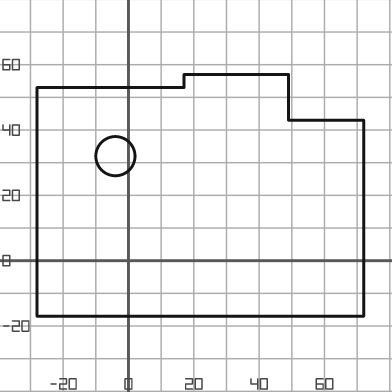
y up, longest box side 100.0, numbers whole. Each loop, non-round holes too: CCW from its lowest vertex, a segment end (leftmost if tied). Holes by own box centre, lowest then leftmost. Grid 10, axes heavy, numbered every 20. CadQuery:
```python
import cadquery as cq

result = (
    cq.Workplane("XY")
    .moveTo(-28.0, -17.0)
    .lineTo(72.0, -17.0)
    .lineTo(72.0, 43.0)
    .lineTo(49.0, 43.0)
    .lineTo(49.0, 57.0)
    .lineTo(17.0, 57.0)
    .lineTo(17.0, 53.0)
    .lineTo(-28.0, 53.0)
    .close()
    .moveTo(-4.0, 32.0)
    .circle(6.0)
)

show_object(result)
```